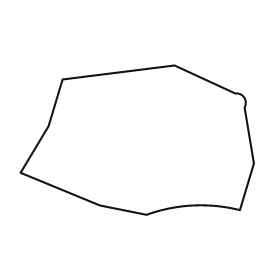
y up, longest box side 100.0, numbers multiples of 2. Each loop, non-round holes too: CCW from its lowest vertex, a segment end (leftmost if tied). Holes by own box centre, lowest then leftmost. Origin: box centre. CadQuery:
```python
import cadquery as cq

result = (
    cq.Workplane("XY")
    .moveTo(4.0, -32.0)
    .threePointArc((24.0, -28.0), (44.0, -30.0))
    .lineTo(50.0, -10.0)
    .lineTo(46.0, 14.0)
    .threePointArc((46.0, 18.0), (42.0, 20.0))
    .lineTo(16.0, 32.0)
    .lineTo(-32.0, 26.0)
    .lineTo(-38.0, 6.0)
    .lineTo(-50.0, -14.0)
    .lineTo(-16.0, -28.0)
    .close()
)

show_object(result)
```